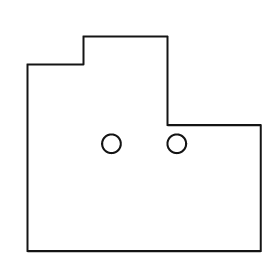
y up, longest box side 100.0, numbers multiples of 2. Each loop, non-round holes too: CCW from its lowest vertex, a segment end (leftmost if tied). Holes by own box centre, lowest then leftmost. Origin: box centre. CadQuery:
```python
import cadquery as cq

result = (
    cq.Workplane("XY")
    .moveTo(-50.0, -46.0)
    .lineTo(50.0, -46.0)
    .lineTo(50.0, 8.0)
    .lineTo(10.0, 8.0)
    .lineTo(10.0, 46.0)
    .lineTo(-26.0, 46.0)
    .lineTo(-26.0, 34.0)
    .lineTo(-50.0, 34.0)
    .close()
    .moveTo(-14.0, 0.0)
    .circle(4.0)
    .moveTo(14.0, 0.0)
    .circle(4.0)
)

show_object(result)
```